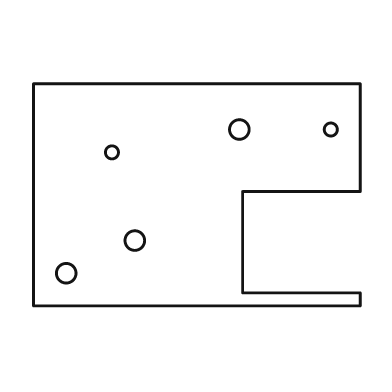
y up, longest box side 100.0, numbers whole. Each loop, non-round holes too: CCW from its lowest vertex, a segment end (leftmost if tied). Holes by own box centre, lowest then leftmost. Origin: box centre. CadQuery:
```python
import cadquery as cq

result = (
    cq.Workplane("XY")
    .moveTo(-50.0, -34.0)
    .lineTo(50.0, -34.0)
    .lineTo(50.0, -30.0)
    .lineTo(14.0, -30.0)
    .lineTo(14.0, 1.0)
    .lineTo(50.0, 1.0)
    .lineTo(50.0, 34.0)
    .lineTo(-50.0, 34.0)
    .close()
    .moveTo(-40.0, -24.0)
    .circle(3.0)
    .moveTo(-19.0, -14.0)
    .circle(3.0)
    .moveTo(-26.0, 13.0)
    .circle(2.0)
    .moveTo(13.0, 20.0)
    .circle(3.0)
    .moveTo(41.0, 20.0)
    .circle(2.0)
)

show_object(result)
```